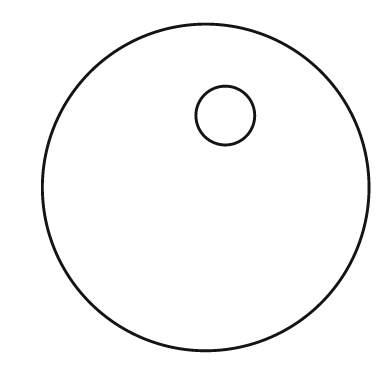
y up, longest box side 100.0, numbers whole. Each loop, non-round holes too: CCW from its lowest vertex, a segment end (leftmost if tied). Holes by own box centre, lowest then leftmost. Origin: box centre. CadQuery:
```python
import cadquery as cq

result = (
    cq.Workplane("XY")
    .moveTo(0.0, 0.0)
    .circle(50.0)
    .moveTo(6.0, 22.0)
    .circle(9.0)
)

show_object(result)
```